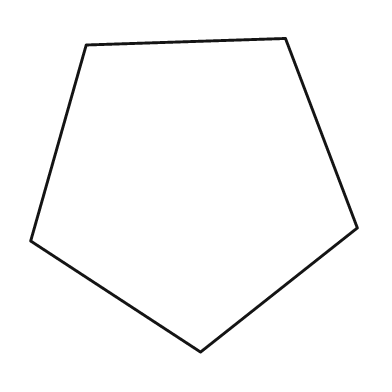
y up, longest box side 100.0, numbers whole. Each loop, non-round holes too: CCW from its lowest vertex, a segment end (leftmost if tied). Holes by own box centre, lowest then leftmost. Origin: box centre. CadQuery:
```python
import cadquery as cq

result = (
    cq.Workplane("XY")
    .moveTo(2.0, -48.0)
    .lineTo(50.0, -10.0)
    .lineTo(28.0, 48.0)
    .lineTo(-33.0, 46.0)
    .lineTo(-50.0, -14.0)
    .close()
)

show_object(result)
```